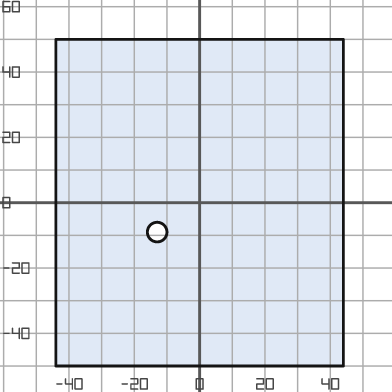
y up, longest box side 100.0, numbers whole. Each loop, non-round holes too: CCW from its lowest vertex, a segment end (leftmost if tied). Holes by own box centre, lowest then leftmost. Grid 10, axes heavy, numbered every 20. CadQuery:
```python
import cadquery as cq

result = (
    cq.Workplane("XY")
    .moveTo(-44.0, -50.0)
    .lineTo(44.0, -50.0)
    .lineTo(44.0, 50.0)
    .lineTo(-44.0, 50.0)
    .close()
    .moveTo(-13.0, -9.0)
    .circle(3.0)
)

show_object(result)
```